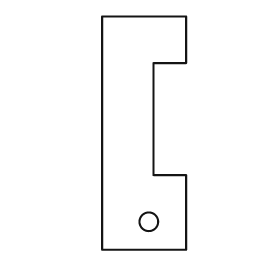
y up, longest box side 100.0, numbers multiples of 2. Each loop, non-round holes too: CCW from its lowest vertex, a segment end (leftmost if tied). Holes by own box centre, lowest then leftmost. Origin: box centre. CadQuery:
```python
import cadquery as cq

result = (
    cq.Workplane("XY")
    .moveTo(-18.0, -50.0)
    .lineTo(18.0, -50.0)
    .lineTo(18.0, -18.0)
    .lineTo(4.0, -18.0)
    .lineTo(4.0, 30.0)
    .lineTo(18.0, 30.0)
    .lineTo(18.0, 50.0)
    .lineTo(-18.0, 50.0)
    .close()
    .moveTo(2.0, -38.0)
    .circle(4.0)
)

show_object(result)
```